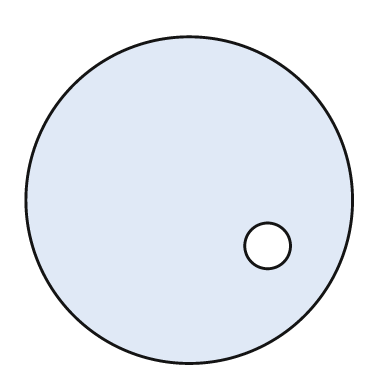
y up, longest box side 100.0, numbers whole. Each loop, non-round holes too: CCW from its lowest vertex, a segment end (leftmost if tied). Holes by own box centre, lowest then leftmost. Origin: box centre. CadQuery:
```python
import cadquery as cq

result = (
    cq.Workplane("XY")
    .moveTo(0.0, 0.0)
    .circle(50.0)
    .moveTo(24.0, -14.0)
    .circle(7.0)
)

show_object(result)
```